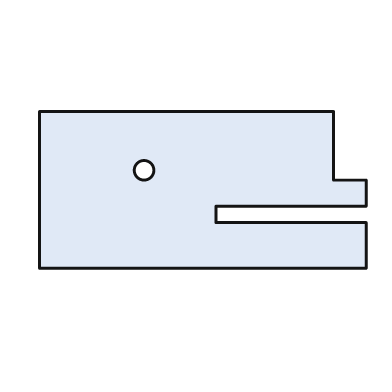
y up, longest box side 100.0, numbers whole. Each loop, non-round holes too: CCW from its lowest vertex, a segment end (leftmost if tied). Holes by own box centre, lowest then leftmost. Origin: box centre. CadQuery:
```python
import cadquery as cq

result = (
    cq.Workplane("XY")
    .moveTo(-50.0, -24.0)
    .lineTo(50.0, -24.0)
    .lineTo(50.0, -10.0)
    .lineTo(4.0, -10.0)
    .lineTo(4.0, -5.0)
    .lineTo(50.0, -5.0)
    .lineTo(50.0, 3.0)
    .lineTo(40.0, 3.0)
    .lineTo(40.0, 24.0)
    .lineTo(-50.0, 24.0)
    .close()
    .moveTo(-18.0, 6.0)
    .circle(3.0)
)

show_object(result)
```